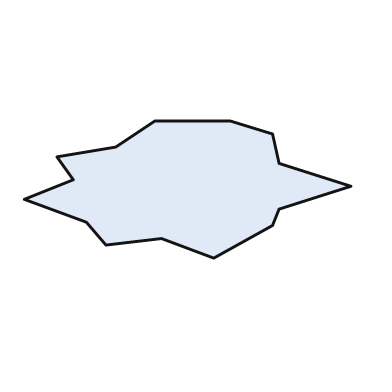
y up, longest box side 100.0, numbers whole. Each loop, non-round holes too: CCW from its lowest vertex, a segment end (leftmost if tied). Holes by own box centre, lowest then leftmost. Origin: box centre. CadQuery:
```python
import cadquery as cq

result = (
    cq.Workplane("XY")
    .moveTo(8.0, -21.0)
    .lineTo(26.0, -11.0)
    .lineTo(28.0, -6.0)
    .lineTo(50.0, 1.0)
    .lineTo(28.0, 8.0)
    .lineTo(26.0, 17.0)
    .lineTo(13.0, 21.0)
    .lineTo(-10.0, 21.0)
    .lineTo(-22.0, 13.0)
    .lineTo(-40.0, 10.0)
    .lineTo(-35.0, 3.0)
    .lineTo(-50.0, -3.0)
    .lineTo(-31.0, -10.0)
    .lineTo(-25.0, -17.0)
    .lineTo(-8.0, -15.0)
    .close()
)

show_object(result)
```